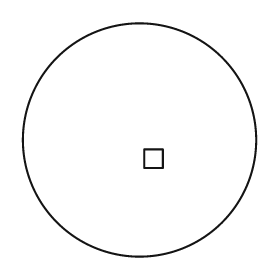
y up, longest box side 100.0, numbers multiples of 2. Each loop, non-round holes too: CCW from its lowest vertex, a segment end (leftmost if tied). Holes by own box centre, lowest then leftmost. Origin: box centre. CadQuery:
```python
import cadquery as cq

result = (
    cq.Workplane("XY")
    .moveTo(0.0, 0.0)
    .circle(50.0)
    .moveTo(2.0, -12.0)
    .lineTo(10.0, -12.0)
    .lineTo(10.0, -4.0)
    .lineTo(2.0, -4.0)
    .close()
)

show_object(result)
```